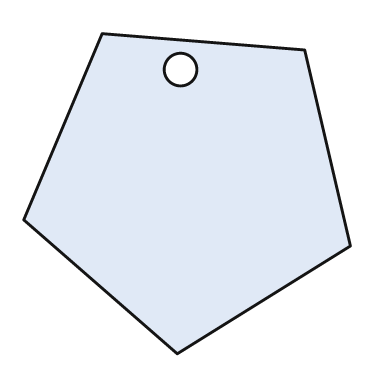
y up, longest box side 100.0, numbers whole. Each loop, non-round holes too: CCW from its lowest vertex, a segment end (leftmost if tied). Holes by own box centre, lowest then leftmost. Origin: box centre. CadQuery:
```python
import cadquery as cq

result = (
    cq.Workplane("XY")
    .moveTo(-3.0, -49.0)
    .lineTo(50.0, -16.0)
    .lineTo(36.0, 44.0)
    .lineTo(-26.0, 49.0)
    .lineTo(-50.0, -8.0)
    .close()
    .moveTo(-2.0, 38.0)
    .circle(5.0)
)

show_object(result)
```